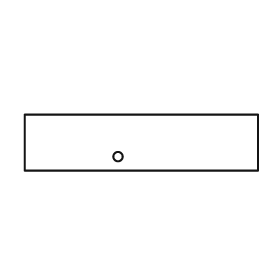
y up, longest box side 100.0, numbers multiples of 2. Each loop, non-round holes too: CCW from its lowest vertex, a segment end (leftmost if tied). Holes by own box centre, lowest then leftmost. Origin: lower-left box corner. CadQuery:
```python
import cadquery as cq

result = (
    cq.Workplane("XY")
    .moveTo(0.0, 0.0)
    .lineTo(100.0, 0.0)
    .lineTo(100.0, 24.0)
    .lineTo(0.0, 24.0)
    .close()
    .moveTo(40.0, 6.0)
    .circle(2.0)
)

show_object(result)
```